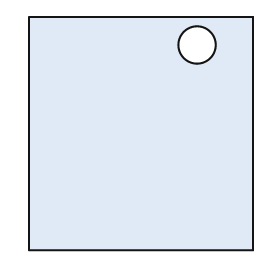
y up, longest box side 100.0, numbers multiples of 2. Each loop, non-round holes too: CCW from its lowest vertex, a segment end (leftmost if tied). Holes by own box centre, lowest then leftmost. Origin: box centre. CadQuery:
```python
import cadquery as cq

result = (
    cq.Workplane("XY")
    .moveTo(-48.0, -50.0)
    .lineTo(48.0, -50.0)
    .lineTo(48.0, 50.0)
    .lineTo(-48.0, 50.0)
    .close()
    .moveTo(24.0, 38.0)
    .circle(8.0)
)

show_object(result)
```